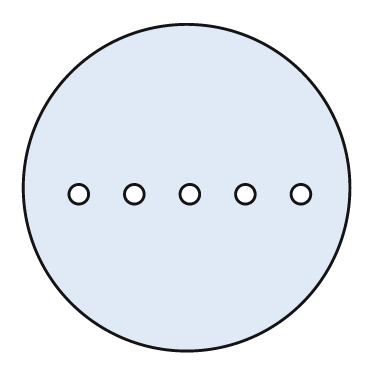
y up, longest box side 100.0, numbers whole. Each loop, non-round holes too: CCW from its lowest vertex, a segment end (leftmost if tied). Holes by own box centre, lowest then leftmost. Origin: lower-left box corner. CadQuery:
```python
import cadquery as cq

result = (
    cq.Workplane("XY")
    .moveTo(50.0, 50.0)
    .circle(50.0)
    .moveTo(17.0, 48.0)
    .circle(3.0)
    .moveTo(34.0, 48.0)
    .circle(3.0)
    .moveTo(51.0, 48.0)
    .circle(3.0)
    .moveTo(68.0, 48.0)
    .circle(3.0)
    .moveTo(85.0, 48.0)
    .circle(3.0)
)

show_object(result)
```